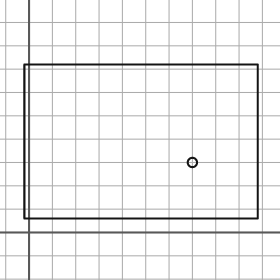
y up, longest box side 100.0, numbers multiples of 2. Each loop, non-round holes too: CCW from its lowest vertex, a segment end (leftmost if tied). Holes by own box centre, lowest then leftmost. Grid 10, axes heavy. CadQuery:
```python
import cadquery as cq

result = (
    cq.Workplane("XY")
    .moveTo(-2.0, 6.0)
    .lineTo(98.0, 6.0)
    .lineTo(98.0, 72.0)
    .lineTo(-2.0, 72.0)
    .close()
    .moveTo(70.0, 30.0)
    .circle(2.0)
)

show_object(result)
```